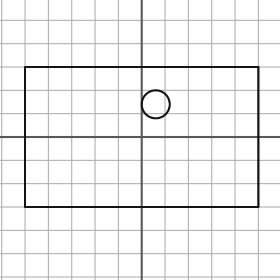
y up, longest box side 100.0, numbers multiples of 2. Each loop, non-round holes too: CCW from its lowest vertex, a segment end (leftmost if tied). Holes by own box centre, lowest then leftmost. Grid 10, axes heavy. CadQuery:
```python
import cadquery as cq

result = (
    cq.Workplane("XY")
    .moveTo(-50.0, -30.0)
    .lineTo(50.0, -30.0)
    .lineTo(50.0, 30.0)
    .lineTo(-50.0, 30.0)
    .close()
    .moveTo(6.0, 14.0)
    .circle(6.0)
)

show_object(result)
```